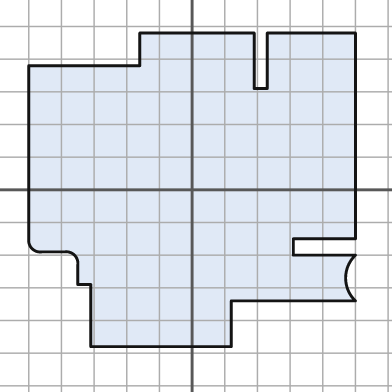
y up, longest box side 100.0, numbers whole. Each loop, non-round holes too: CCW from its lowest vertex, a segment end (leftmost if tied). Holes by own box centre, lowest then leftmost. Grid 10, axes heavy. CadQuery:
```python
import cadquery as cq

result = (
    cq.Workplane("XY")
    .moveTo(-31.0, -48.0)
    .lineTo(12.0, -48.0)
    .lineTo(12.0, -34.0)
    .lineTo(50.0, -34.0)
    .threePointArc((47.0, -27.0), (50.0, -20.0))
    .lineTo(31.0, -20.0)
    .lineTo(31.0, -15.0)
    .lineTo(50.0, -15.0)
    .lineTo(50.0, 48.0)
    .lineTo(23.0, 48.0)
    .lineTo(23.0, 31.0)
    .lineTo(19.0, 31.0)
    .lineTo(19.0, 48.0)
    .lineTo(-16.0, 48.0)
    .lineTo(-16.0, 38.0)
    .lineTo(-50.0, 38.0)
    .lineTo(-50.0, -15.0)
    .threePointArc((-49.0, -18.0), (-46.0, -19.0))
    .lineTo(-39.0, -19.0)
    .threePointArc((-36.0, -20.0), (-35.0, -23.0))
    .lineTo(-35.0, -29.0)
    .lineTo(-31.0, -29.0)
    .close()
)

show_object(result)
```